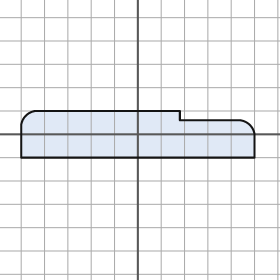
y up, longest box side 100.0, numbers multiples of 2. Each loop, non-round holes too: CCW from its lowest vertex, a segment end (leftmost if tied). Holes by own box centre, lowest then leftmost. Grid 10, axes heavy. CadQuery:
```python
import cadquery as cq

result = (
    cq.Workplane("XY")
    .moveTo(-50.0, -10.0)
    .lineTo(50.0, -10.0)
    .lineTo(50.0, 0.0)
    .threePointArc((48.0, 4.0), (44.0, 6.0))
    .lineTo(18.0, 6.0)
    .lineTo(18.0, 10.0)
    .lineTo(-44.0, 10.0)
    .threePointArc((-48.0, 8.0), (-50.0, 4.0))
    .close()
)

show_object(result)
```